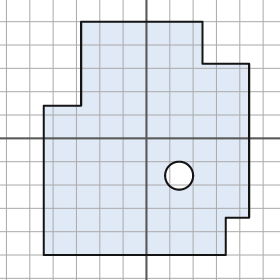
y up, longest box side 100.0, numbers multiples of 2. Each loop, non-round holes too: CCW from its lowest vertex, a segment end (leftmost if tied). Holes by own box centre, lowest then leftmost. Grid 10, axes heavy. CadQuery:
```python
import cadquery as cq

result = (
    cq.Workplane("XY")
    .moveTo(-44.0, -50.0)
    .lineTo(34.0, -50.0)
    .lineTo(34.0, -34.0)
    .lineTo(44.0, -34.0)
    .lineTo(44.0, 32.0)
    .lineTo(24.0, 32.0)
    .lineTo(24.0, 50.0)
    .lineTo(-28.0, 50.0)
    .lineTo(-28.0, 14.0)
    .lineTo(-44.0, 14.0)
    .close()
    .moveTo(14.0, -16.0)
    .circle(6.0)
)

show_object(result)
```